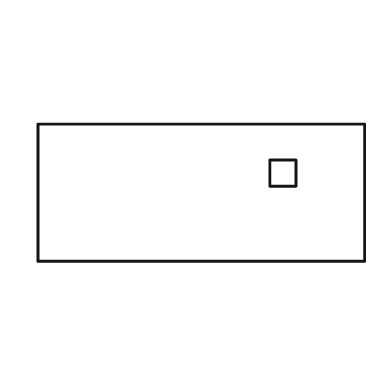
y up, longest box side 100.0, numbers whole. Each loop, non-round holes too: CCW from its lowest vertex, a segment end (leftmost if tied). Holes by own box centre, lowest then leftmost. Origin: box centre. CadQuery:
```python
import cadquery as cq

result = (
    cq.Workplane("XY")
    .moveTo(-50.0, -21.0)
    .lineTo(50.0, -21.0)
    .lineTo(50.0, 21.0)
    .lineTo(-50.0, 21.0)
    .close()
    .moveTo(21.0, 2.0)
    .lineTo(29.0, 2.0)
    .lineTo(29.0, 10.0)
    .lineTo(21.0, 10.0)
    .close()
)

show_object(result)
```